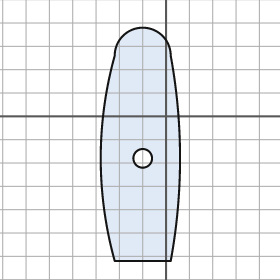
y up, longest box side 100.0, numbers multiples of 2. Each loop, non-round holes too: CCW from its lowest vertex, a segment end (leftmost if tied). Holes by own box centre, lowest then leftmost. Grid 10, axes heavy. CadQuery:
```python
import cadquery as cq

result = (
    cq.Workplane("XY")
    .moveTo(-22.0, -62.0)
    .lineTo(2.0, -62.0)
    .threePointArc((6.0, -18.0), (2.0, 26.0))
    .threePointArc((-10.0, 38.0), (-22.0, 26.0))
    .threePointArc((-28.0, -18.0), (-22.0, -62.0))
    .close()
    .moveTo(-10.0, -18.0)
    .circle(4.0)
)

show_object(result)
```